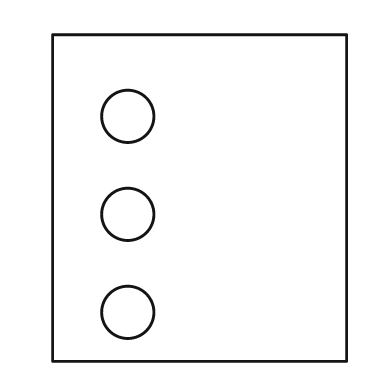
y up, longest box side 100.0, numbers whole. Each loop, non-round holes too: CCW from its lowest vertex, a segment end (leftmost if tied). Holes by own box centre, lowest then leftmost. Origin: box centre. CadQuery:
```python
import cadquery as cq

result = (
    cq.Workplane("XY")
    .moveTo(-45.0, -50.0)
    .lineTo(45.0, -50.0)
    .lineTo(45.0, 50.0)
    .lineTo(-45.0, 50.0)
    .close()
    .moveTo(-22.0, -35.0)
    .circle(8.0)
    .moveTo(-22.0, -5.0)
    .circle(8.0)
    .moveTo(-22.0, 25.0)
    .circle(8.0)
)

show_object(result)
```